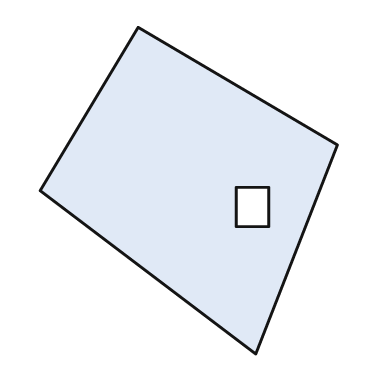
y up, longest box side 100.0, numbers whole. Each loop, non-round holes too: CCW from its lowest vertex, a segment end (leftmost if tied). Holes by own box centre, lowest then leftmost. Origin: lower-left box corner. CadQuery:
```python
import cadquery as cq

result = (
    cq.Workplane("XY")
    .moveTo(66.0, 0.0)
    .lineTo(91.0, 64.0)
    .lineTo(30.0, 100.0)
    .lineTo(0.0, 50.0)
    .close()
    .moveTo(60.0, 39.0)
    .lineTo(70.0, 39.0)
    .lineTo(70.0, 51.0)
    .lineTo(60.0, 51.0)
    .close()
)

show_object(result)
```